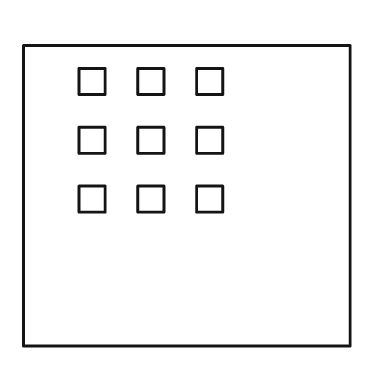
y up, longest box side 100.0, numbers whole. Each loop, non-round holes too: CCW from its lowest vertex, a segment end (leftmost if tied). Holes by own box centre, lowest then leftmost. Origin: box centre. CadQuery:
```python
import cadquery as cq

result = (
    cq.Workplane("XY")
    .moveTo(-50.0, -46.0)
    .lineTo(50.0, -46.0)
    .lineTo(50.0, 46.0)
    .lineTo(-50.0, 46.0)
    .close()
    .moveTo(-33.0, -5.0)
    .lineTo(-25.0, -5.0)
    .lineTo(-25.0, 3.0)
    .lineTo(-33.0, 3.0)
    .close()
    .moveTo(-15.0, -5.0)
    .lineTo(-7.0, -5.0)
    .lineTo(-7.0, 3.0)
    .lineTo(-15.0, 3.0)
    .close()
    .moveTo(3.0, -5.0)
    .lineTo(11.0, -5.0)
    .lineTo(11.0, 3.0)
    .lineTo(3.0, 3.0)
    .close()
    .moveTo(-33.0, 13.0)
    .lineTo(-25.0, 13.0)
    .lineTo(-25.0, 21.0)
    .lineTo(-33.0, 21.0)
    .close()
    .moveTo(-15.0, 13.0)
    .lineTo(-7.0, 13.0)
    .lineTo(-7.0, 21.0)
    .lineTo(-15.0, 21.0)
    .close()
    .moveTo(3.0, 13.0)
    .lineTo(11.0, 13.0)
    .lineTo(11.0, 21.0)
    .lineTo(3.0, 21.0)
    .close()
    .moveTo(-33.0, 31.0)
    .lineTo(-25.0, 31.0)
    .lineTo(-25.0, 39.0)
    .lineTo(-33.0, 39.0)
    .close()
    .moveTo(-15.0, 31.0)
    .lineTo(-7.0, 31.0)
    .lineTo(-7.0, 39.0)
    .lineTo(-15.0, 39.0)
    .close()
    .moveTo(3.0, 31.0)
    .lineTo(11.0, 31.0)
    .lineTo(11.0, 39.0)
    .lineTo(3.0, 39.0)
    .close()
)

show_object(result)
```